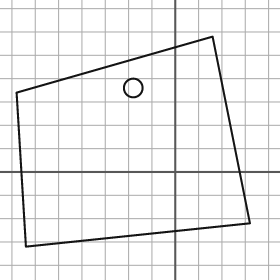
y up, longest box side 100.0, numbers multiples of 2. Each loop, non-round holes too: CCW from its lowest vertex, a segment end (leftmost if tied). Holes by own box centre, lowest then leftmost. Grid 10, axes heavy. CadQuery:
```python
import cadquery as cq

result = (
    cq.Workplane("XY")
    .moveTo(-64.0, -32.0)
    .lineTo(32.0, -22.0)
    .lineTo(16.0, 58.0)
    .lineTo(-68.0, 34.0)
    .close()
    .moveTo(-18.0, 36.0)
    .circle(4.0)
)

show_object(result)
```